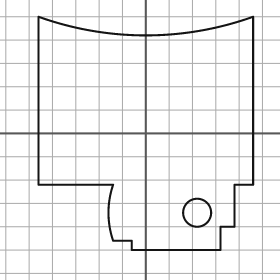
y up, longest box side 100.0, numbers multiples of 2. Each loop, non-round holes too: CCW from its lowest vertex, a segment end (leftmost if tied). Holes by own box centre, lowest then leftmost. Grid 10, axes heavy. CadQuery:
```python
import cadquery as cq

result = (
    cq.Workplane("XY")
    .moveTo(-6.0, -50.0)
    .lineTo(32.0, -50.0)
    .lineTo(32.0, -40.0)
    .lineTo(38.0, -40.0)
    .lineTo(38.0, -22.0)
    .lineTo(46.0, -22.0)
    .lineTo(46.0, 50.0)
    .threePointArc((0.0, 42.0), (-46.0, 50.0))
    .lineTo(-46.0, -22.0)
    .lineTo(-14.0, -22.0)
    .threePointArc((-16.0, -34.0), (-14.0, -46.0))
    .lineTo(-6.0, -46.0)
    .close()
    .moveTo(22.0, -34.0)
    .circle(6.0)
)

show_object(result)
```